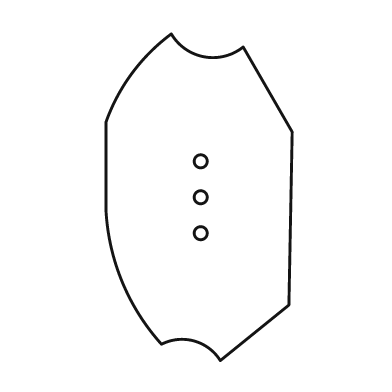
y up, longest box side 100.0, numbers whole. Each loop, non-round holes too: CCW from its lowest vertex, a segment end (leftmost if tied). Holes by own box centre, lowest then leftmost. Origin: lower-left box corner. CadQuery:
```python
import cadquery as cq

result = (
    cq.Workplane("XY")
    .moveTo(35.0, 0.0)
    .lineTo(56.0, 17.0)
    .lineTo(57.0, 70.0)
    .lineTo(42.0, 96.0)
    .threePointArc((30.0, 93.0), (20.0, 100.0))
    .threePointArc((8.0, 88.0), (0.0, 73.0))
    .lineTo(0.0, 46.0)
    .threePointArc((5.0, 24.0), (17.0, 5.0))
    .threePointArc((27.0, 6.0), (35.0, 0.0))
    .close()
    .moveTo(29.0, 39.0)
    .circle(2.0)
    .moveTo(29.0, 50.0)
    .circle(2.0)
    .moveTo(29.0, 61.0)
    .circle(2.0)
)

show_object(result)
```